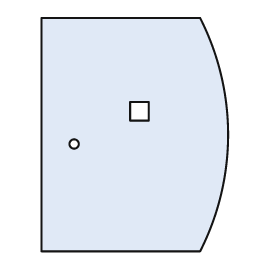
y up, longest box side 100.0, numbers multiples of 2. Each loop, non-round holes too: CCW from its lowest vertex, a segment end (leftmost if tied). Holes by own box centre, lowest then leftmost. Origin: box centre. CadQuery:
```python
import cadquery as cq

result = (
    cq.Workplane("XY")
    .moveTo(-40.0, -50.0)
    .lineTo(28.0, -50.0)
    .threePointArc((40.0, 0.0), (28.0, 50.0))
    .lineTo(-40.0, 50.0)
    .close()
    .moveTo(-26.0, -4.0)
    .circle(2.0)
    .moveTo(-2.0, 6.0)
    .lineTo(6.0, 6.0)
    .lineTo(6.0, 14.0)
    .lineTo(-2.0, 14.0)
    .close()
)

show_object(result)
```